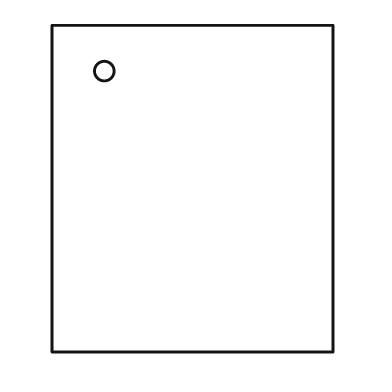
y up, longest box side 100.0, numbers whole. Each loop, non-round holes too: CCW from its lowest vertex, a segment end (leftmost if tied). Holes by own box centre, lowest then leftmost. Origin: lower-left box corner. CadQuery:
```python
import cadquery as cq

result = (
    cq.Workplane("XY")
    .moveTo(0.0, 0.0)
    .lineTo(86.0, 0.0)
    .lineTo(86.0, 100.0)
    .lineTo(0.0, 100.0)
    .close()
    .moveTo(16.0, 86.0)
    .circle(3.0)
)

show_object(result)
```